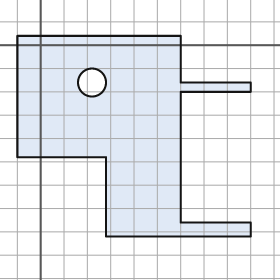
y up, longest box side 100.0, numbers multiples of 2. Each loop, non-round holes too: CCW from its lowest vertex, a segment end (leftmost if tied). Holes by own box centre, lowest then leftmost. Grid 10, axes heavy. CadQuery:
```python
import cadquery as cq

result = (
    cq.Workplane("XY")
    .moveTo(28.0, -82.0)
    .lineTo(90.0, -82.0)
    .lineTo(90.0, -76.0)
    .lineTo(60.0, -76.0)
    .lineTo(60.0, -20.0)
    .lineTo(90.0, -20.0)
    .lineTo(90.0, -16.0)
    .lineTo(60.0, -16.0)
    .lineTo(60.0, 4.0)
    .lineTo(-10.0, 4.0)
    .lineTo(-10.0, -48.0)
    .lineTo(28.0, -48.0)
    .close()
    .moveTo(22.0, -16.0)
    .circle(6.0)
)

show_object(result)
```